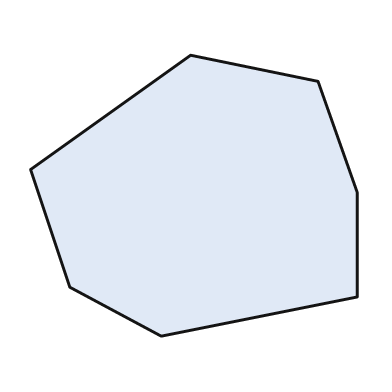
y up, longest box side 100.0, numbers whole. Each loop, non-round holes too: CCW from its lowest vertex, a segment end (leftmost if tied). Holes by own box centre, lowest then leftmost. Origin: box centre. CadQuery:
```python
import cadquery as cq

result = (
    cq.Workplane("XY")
    .moveTo(-10.0, -43.0)
    .lineTo(50.0, -31.0)
    .lineTo(50.0, 1.0)
    .lineTo(38.0, 35.0)
    .lineTo(-1.0, 43.0)
    .lineTo(-50.0, 8.0)
    .lineTo(-38.0, -28.0)
    .close()
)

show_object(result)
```